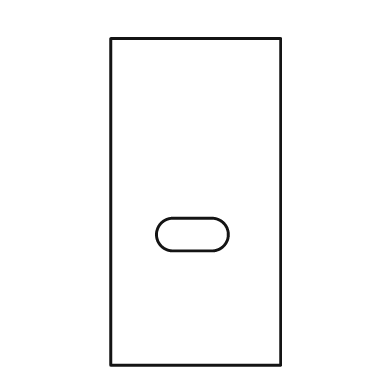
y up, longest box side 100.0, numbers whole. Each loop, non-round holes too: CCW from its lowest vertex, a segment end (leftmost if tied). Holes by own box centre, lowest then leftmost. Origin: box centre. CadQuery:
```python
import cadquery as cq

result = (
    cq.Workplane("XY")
    .moveTo(-26.0, -50.0)
    .lineTo(26.0, -50.0)
    .lineTo(26.0, 50.0)
    .lineTo(-26.0, 50.0)
    .close()
    .moveTo(-7.0, -15.0)
    .lineTo(5.0, -15.0)
    .threePointArc((10.0, -10.0), (5.0, -5.0))
    .lineTo(-7.0, -5.0)
    .threePointArc((-12.0, -10.0), (-7.0, -15.0))
    .close()
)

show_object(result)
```